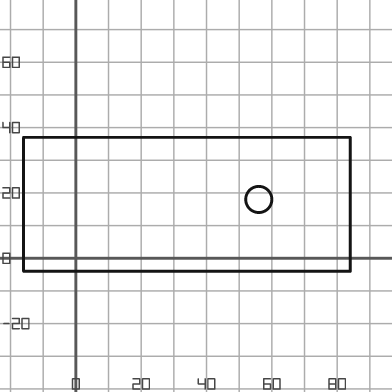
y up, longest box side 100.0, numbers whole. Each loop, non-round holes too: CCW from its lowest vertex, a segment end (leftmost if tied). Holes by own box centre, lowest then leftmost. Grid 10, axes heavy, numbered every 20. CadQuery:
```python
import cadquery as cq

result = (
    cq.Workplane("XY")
    .moveTo(-16.0, -4.0)
    .lineTo(84.0, -4.0)
    .lineTo(84.0, 37.0)
    .lineTo(-16.0, 37.0)
    .close()
    .moveTo(56.0, 18.0)
    .circle(4.0)
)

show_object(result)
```